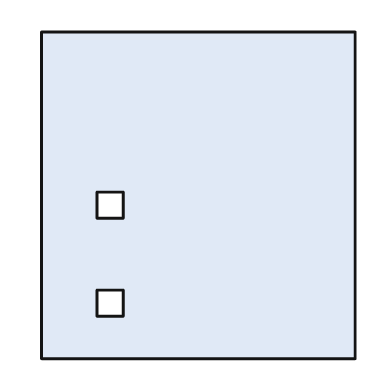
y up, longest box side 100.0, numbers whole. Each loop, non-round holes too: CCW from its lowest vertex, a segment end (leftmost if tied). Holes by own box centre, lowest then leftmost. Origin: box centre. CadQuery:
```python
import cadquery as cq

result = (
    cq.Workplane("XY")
    .moveTo(-48.0, -50.0)
    .lineTo(48.0, -50.0)
    .lineTo(48.0, 50.0)
    .lineTo(-48.0, 50.0)
    .close()
    .moveTo(-31.0, -37.0)
    .lineTo(-23.0, -37.0)
    .lineTo(-23.0, -29.0)
    .lineTo(-31.0, -29.0)
    .close()
    .moveTo(-31.0, -7.0)
    .lineTo(-23.0, -7.0)
    .lineTo(-23.0, 1.0)
    .lineTo(-31.0, 1.0)
    .close()
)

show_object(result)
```